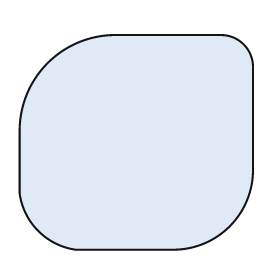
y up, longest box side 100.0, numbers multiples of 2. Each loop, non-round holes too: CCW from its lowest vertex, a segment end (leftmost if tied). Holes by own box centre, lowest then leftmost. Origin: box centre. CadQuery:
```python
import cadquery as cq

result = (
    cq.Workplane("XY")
    .moveTo(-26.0, -46.0)
    .lineTo(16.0, -46.0)
    .threePointArc((40.0, -36.0), (50.0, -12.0))
    .lineTo(50.0, 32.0)
    .threePointArc((46.0, 42.0), (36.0, 46.0))
    .lineTo(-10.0, 46.0)
    .threePointArc((-38.0, 34.0), (-50.0, 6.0))
    .lineTo(-50.0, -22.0)
    .threePointArc((-42.0, -38.0), (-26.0, -46.0))
    .close()
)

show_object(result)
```